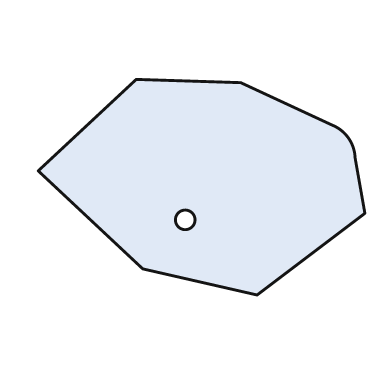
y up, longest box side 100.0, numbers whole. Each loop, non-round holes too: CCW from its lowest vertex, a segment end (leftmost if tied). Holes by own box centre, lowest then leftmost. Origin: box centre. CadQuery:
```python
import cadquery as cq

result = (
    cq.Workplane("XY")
    .moveTo(17.0, -33.0)
    .lineTo(50.0, -8.0)
    .lineTo(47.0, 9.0)
    .threePointArc((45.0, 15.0), (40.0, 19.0))
    .lineTo(12.0, 32.0)
    .lineTo(-20.0, 33.0)
    .lineTo(-50.0, 5.0)
    .lineTo(-18.0, -25.0)
    .close()
    .moveTo(-5.0, -10.0)
    .circle(3.0)
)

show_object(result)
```